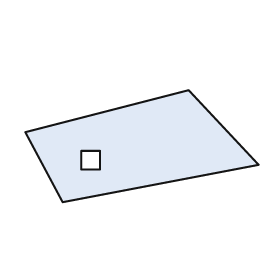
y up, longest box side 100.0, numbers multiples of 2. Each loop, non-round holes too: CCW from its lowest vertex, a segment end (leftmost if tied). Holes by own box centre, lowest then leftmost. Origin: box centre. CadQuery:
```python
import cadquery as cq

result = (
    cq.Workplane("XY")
    .moveTo(-34.0, -24.0)
    .lineTo(50.0, -8.0)
    .lineTo(20.0, 24.0)
    .lineTo(-50.0, 6.0)
    .close()
    .moveTo(-26.0, -10.0)
    .lineTo(-18.0, -10.0)
    .lineTo(-18.0, -2.0)
    .lineTo(-26.0, -2.0)
    .close()
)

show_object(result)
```